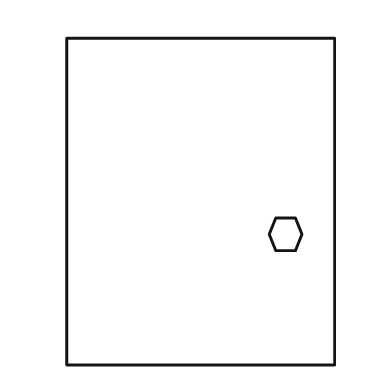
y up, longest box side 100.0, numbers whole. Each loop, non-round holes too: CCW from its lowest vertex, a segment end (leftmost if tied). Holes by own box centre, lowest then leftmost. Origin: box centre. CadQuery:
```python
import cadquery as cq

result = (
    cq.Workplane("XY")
    .moveTo(-41.0, -50.0)
    .lineTo(41.0, -50.0)
    .lineTo(41.0, 50.0)
    .lineTo(-41.0, 50.0)
    .close()
    .moveTo(23.0, -15.0)
    .lineTo(29.0, -15.0)
    .lineTo(31.0, -10.0)
    .lineTo(29.0, -5.0)
    .lineTo(23.0, -5.0)
    .lineTo(21.0, -10.0)
    .close()
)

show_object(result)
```